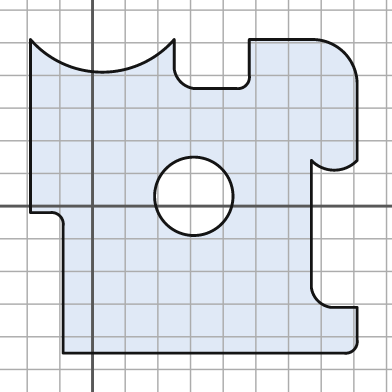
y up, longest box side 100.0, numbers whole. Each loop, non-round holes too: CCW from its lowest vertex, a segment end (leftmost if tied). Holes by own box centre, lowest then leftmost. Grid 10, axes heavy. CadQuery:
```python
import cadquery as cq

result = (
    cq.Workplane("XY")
    .moveTo(-9.0, -45.0)
    .lineTo(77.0, -45.0)
    .threePointArc((80.0, -44.0), (81.0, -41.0))
    .lineTo(81.0, -31.0)
    .lineTo(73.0, -31.0)
    .threePointArc((69.0, -29.0), (67.0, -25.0))
    .lineTo(67.0, 14.0)
    .threePointArc((74.0, 11.0), (81.0, 14.0))
    .lineTo(81.0, 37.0)
    .threePointArc((77.0, 47.0), (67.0, 51.0))
    .lineTo(48.0, 51.0)
    .lineTo(48.0, 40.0)
    .threePointArc((47.0, 37.0), (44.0, 36.0))
    .lineTo(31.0, 36.0)
    .threePointArc((27.0, 38.0), (25.0, 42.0))
    .lineTo(25.0, 51.0)
    .threePointArc((3.0, 41.0), (-19.0, 51.0))
    .lineTo(-19.0, -2.0)
    .lineTo(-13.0, -2.0)
    .threePointArc((-10.0, -3.0), (-9.0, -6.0))
    .close()
    .moveTo(31.0, 3.0)
    .circle(12.0)
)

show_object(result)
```